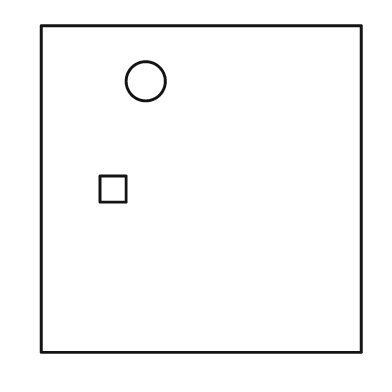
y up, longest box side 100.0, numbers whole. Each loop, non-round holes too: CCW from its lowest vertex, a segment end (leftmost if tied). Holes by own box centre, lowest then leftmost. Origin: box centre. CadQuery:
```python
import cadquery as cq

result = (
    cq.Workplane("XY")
    .moveTo(-49.0, -50.0)
    .lineTo(49.0, -50.0)
    .lineTo(49.0, 50.0)
    .lineTo(-49.0, 50.0)
    .close()
    .moveTo(-31.0, -4.0)
    .lineTo(-23.0, -4.0)
    .lineTo(-23.0, 4.0)
    .lineTo(-31.0, 4.0)
    .close()
    .moveTo(-17.0, 33.0)
    .circle(6.0)
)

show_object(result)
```